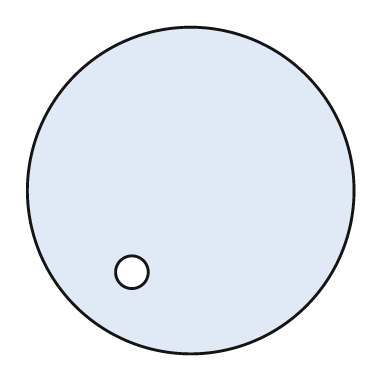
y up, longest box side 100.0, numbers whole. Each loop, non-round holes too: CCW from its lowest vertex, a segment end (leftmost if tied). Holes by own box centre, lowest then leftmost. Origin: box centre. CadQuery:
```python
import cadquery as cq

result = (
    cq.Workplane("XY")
    .moveTo(0.0, 0.0)
    .circle(50.0)
    .moveTo(-18.0, -25.0)
    .circle(5.0)
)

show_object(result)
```